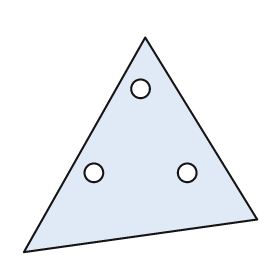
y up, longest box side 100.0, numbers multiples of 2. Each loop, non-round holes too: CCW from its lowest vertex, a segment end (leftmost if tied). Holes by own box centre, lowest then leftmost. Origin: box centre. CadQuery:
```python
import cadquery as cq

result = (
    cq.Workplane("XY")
    .moveTo(-50.0, -46.0)
    .lineTo(50.0, -32.0)
    .lineTo(2.0, 46.0)
    .close()
    .moveTo(-20.0, -12.0)
    .circle(4.0)
    .moveTo(20.0, -12.0)
    .circle(4.0)
    .moveTo(0.0, 24.0)
    .circle(4.0)
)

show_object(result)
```